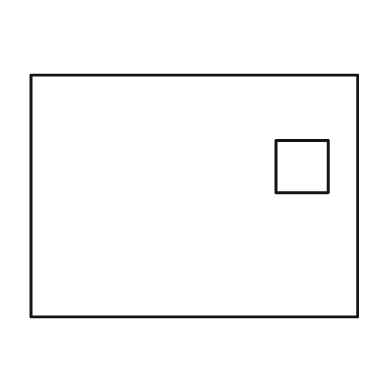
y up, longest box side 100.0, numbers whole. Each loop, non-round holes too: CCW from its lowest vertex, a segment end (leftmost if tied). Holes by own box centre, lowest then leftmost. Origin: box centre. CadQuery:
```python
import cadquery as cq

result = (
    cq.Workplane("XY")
    .moveTo(-50.0, -37.0)
    .lineTo(50.0, -37.0)
    .lineTo(50.0, 37.0)
    .lineTo(-50.0, 37.0)
    .close()
    .moveTo(25.0, 1.0)
    .lineTo(41.0, 1.0)
    .lineTo(41.0, 17.0)
    .lineTo(25.0, 17.0)
    .close()
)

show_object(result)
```